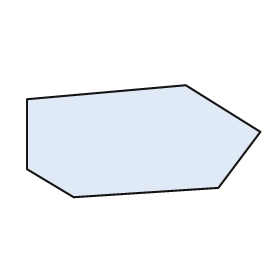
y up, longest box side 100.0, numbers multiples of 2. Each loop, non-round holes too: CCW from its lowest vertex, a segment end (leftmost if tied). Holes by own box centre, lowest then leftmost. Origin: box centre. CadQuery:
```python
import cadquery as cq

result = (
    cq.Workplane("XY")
    .moveTo(-30.0, -24.0)
    .lineTo(32.0, -20.0)
    .lineTo(50.0, 4.0)
    .lineTo(18.0, 24.0)
    .lineTo(-50.0, 18.0)
    .lineTo(-50.0, -12.0)
    .close()
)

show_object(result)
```